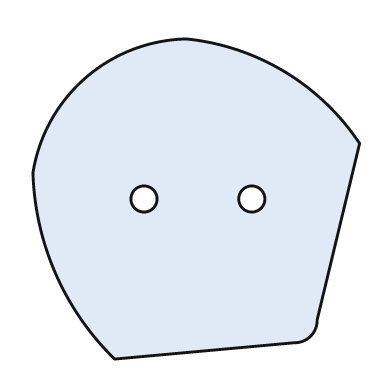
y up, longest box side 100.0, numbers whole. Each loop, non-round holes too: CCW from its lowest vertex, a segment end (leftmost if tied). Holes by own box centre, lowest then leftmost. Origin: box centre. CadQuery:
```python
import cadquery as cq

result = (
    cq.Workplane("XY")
    .moveTo(-25.0, -49.0)
    .lineTo(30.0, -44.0)
    .threePointArc((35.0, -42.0), (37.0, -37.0))
    .lineTo(50.0, 17.0)
    .threePointArc((27.0, 39.0), (-3.0, 49.0))
    .threePointArc((-34.0, 37.0), (-50.0, 8.0))
    .threePointArc((-43.0, -23.0), (-25.0, -49.0))
    .close()
    .moveTo(-16.0, 0.0)
    .circle(4.0)
    .moveTo(17.0, 0.0)
    .circle(4.0)
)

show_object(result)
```